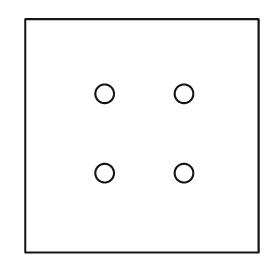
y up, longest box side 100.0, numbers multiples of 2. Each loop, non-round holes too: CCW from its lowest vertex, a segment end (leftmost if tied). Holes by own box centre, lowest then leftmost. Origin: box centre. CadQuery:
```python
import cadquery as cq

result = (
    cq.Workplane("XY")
    .moveTo(-50.0, -50.0)
    .lineTo(50.0, -50.0)
    .lineTo(50.0, 50.0)
    .lineTo(-50.0, 50.0)
    .close()
    .moveTo(-16.0, -16.0)
    .circle(4.0)
    .moveTo(18.0, -16.0)
    .circle(4.0)
    .moveTo(-16.0, 18.0)
    .circle(4.0)
    .moveTo(18.0, 18.0)
    .circle(4.0)
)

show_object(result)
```